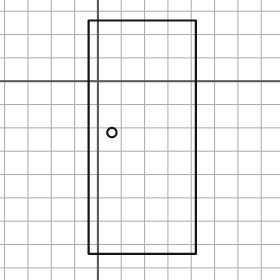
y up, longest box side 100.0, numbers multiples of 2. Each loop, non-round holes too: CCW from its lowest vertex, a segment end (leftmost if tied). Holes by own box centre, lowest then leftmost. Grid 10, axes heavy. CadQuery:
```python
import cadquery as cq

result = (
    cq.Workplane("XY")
    .moveTo(-4.0, -74.0)
    .lineTo(42.0, -74.0)
    .lineTo(42.0, 26.0)
    .lineTo(-4.0, 26.0)
    .close()
    .moveTo(6.0, -22.0)
    .circle(2.0)
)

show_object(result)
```